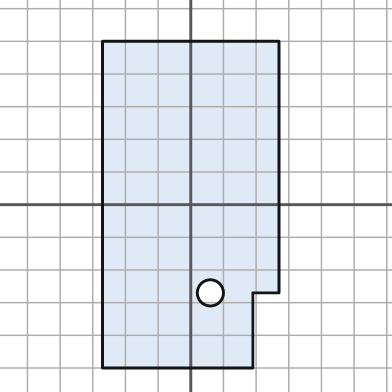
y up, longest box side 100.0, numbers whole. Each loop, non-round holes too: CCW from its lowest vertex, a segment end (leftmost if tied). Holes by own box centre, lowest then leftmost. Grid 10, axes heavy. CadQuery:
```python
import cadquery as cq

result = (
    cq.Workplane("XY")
    .moveTo(-27.0, -50.0)
    .lineTo(19.0, -50.0)
    .lineTo(19.0, -27.0)
    .lineTo(27.0, -27.0)
    .lineTo(27.0, 50.0)
    .lineTo(-27.0, 50.0)
    .close()
    .moveTo(6.0, -27.0)
    .circle(4.0)
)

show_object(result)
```